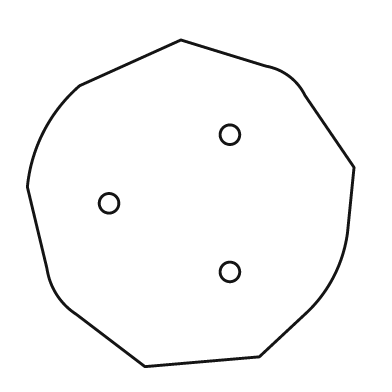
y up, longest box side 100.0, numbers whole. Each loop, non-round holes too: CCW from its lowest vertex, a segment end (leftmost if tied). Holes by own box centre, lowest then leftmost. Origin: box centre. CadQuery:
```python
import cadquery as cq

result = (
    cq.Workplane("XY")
    .moveTo(-14.0, -50.0)
    .lineTo(21.0, -47.0)
    .lineTo(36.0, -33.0)
    .threePointArc((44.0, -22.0), (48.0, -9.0))
    .lineTo(50.0, 11.0)
    .lineTo(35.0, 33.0)
    .threePointArc((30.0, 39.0), (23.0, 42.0))
    .lineTo(-3.0, 50.0)
    .lineTo(-34.0, 36.0)
    .threePointArc((-45.0, 22.0), (-50.0, 5.0))
    .lineTo(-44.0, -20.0)
    .threePointArc((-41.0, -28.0), (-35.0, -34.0))
    .close()
    .moveTo(12.0, -21.0)
    .circle(3.0)
    .moveTo(-25.0, 0.0)
    .circle(3.0)
    .moveTo(12.0, 21.0)
    .circle(3.0)
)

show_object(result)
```